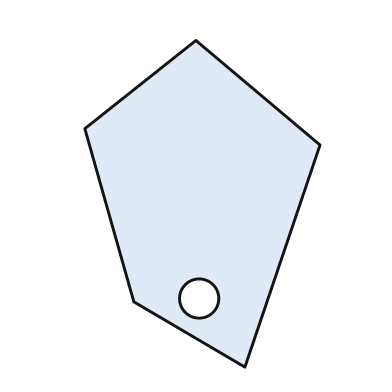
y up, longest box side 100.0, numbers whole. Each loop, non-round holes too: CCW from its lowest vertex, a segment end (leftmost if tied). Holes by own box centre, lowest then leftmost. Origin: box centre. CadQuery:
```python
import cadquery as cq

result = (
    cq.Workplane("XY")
    .moveTo(13.0, -50.0)
    .lineTo(36.0, 18.0)
    .lineTo(-2.0, 50.0)
    .lineTo(-36.0, 23.0)
    .lineTo(-21.0, -30.0)
    .close()
    .moveTo(-1.0, -29.0)
    .circle(6.0)
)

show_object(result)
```